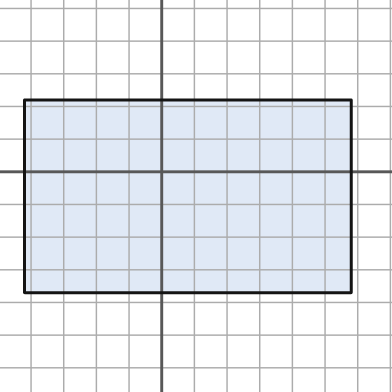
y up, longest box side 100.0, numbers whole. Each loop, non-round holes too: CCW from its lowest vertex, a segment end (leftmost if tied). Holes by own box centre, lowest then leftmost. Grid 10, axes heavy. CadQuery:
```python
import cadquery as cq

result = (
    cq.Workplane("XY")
    .moveTo(-42.0, -37.0)
    .lineTo(58.0, -37.0)
    .lineTo(58.0, 22.0)
    .lineTo(-42.0, 22.0)
    .close()
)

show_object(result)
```